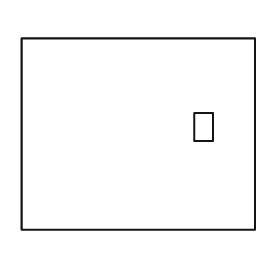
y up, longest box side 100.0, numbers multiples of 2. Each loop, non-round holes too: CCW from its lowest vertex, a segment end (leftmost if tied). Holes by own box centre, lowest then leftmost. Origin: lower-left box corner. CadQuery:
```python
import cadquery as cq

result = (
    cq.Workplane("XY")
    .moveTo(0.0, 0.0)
    .lineTo(100.0, 0.0)
    .lineTo(100.0, 82.0)
    .lineTo(0.0, 82.0)
    .close()
    .moveTo(74.0, 38.0)
    .lineTo(82.0, 38.0)
    .lineTo(82.0, 50.0)
    .lineTo(74.0, 50.0)
    .close()
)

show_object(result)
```